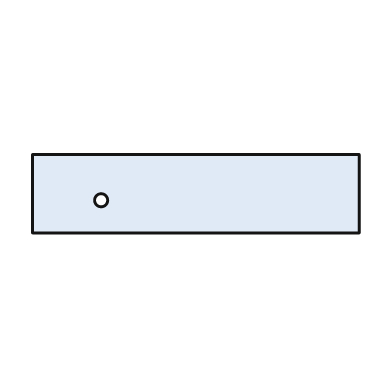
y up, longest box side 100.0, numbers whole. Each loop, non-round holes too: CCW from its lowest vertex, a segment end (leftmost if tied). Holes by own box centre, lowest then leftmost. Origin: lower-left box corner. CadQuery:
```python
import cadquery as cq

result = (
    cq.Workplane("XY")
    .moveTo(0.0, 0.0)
    .lineTo(100.0, 0.0)
    .lineTo(100.0, 24.0)
    .lineTo(0.0, 24.0)
    .close()
    .moveTo(21.0, 10.0)
    .circle(2.0)
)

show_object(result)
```